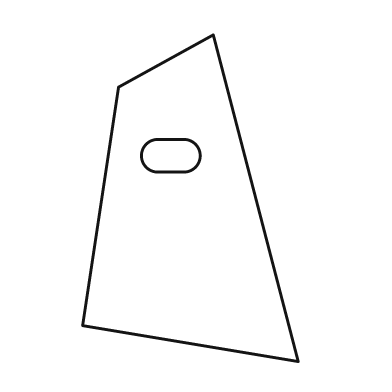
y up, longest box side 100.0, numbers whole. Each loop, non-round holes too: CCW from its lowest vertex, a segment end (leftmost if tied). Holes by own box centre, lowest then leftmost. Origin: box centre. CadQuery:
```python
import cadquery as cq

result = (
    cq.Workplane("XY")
    .moveTo(33.0, -50.0)
    .lineTo(7.0, 50.0)
    .lineTo(-22.0, 34.0)
    .lineTo(-33.0, -39.0)
    .close()
    .moveTo(-10.0, 8.0)
    .lineTo(-2.0, 8.0)
    .threePointArc((3.0, 13.0), (-2.0, 18.0))
    .lineTo(-10.0, 18.0)
    .threePointArc((-15.0, 13.0), (-10.0, 8.0))
    .close()
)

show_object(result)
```